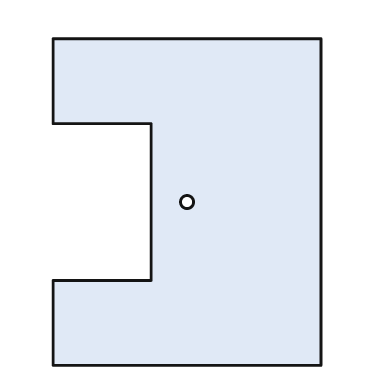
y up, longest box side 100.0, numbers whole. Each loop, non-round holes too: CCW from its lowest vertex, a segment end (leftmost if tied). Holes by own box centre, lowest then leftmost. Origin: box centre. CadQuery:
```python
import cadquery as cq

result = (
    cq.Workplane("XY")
    .moveTo(-41.0, -50.0)
    .lineTo(41.0, -50.0)
    .lineTo(41.0, 50.0)
    .lineTo(-41.0, 50.0)
    .lineTo(-41.0, 24.0)
    .lineTo(-11.0, 24.0)
    .lineTo(-11.0, -24.0)
    .lineTo(-41.0, -24.0)
    .close()
    .moveTo(0.0, 0.0)
    .circle(2.0)
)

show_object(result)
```